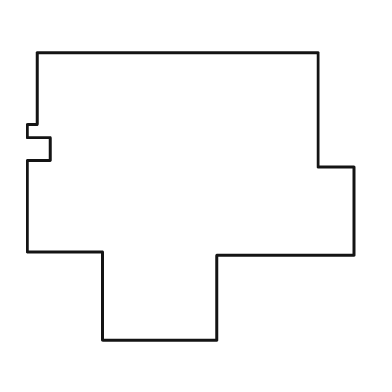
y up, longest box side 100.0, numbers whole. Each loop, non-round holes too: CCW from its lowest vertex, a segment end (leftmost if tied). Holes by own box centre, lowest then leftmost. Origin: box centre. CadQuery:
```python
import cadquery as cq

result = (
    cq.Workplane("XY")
    .moveTo(-27.0, -44.0)
    .lineTo(8.0, -44.0)
    .lineTo(8.0, -18.0)
    .lineTo(50.0, -18.0)
    .lineTo(50.0, 9.0)
    .lineTo(39.0, 9.0)
    .lineTo(39.0, 44.0)
    .lineTo(-47.0, 44.0)
    .lineTo(-47.0, 22.0)
    .lineTo(-50.0, 22.0)
    .lineTo(-50.0, 18.0)
    .lineTo(-43.0, 18.0)
    .lineTo(-43.0, 11.0)
    .lineTo(-50.0, 11.0)
    .lineTo(-50.0, -17.0)
    .lineTo(-27.0, -17.0)
    .close()
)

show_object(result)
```